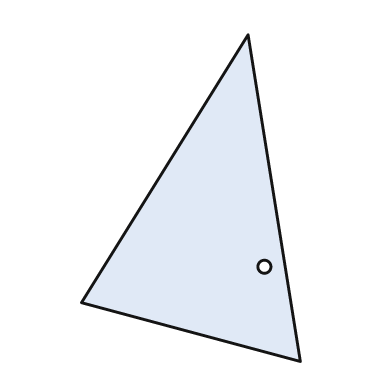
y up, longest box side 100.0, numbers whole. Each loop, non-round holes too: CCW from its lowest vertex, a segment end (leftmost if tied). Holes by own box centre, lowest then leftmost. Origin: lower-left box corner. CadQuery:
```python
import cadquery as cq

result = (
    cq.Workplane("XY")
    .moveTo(67.0, 0.0)
    .lineTo(51.0, 100.0)
    .lineTo(0.0, 18.0)
    .close()
    .moveTo(56.0, 29.0)
    .circle(2.0)
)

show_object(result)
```